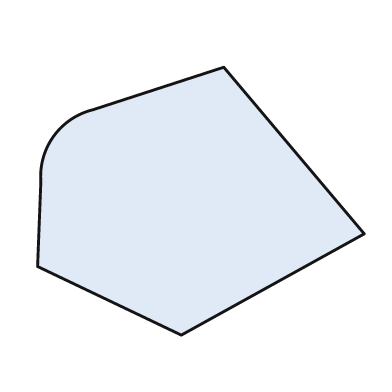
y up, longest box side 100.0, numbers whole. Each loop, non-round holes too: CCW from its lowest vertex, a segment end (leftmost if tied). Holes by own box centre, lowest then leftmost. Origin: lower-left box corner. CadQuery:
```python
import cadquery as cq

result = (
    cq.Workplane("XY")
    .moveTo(44.0, 0.0)
    .lineTo(100.0, 31.0)
    .lineTo(57.0, 82.0)
    .lineTo(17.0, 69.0)
    .threePointArc((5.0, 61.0), (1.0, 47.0))
    .lineTo(0.0, 21.0)
    .close()
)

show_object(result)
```